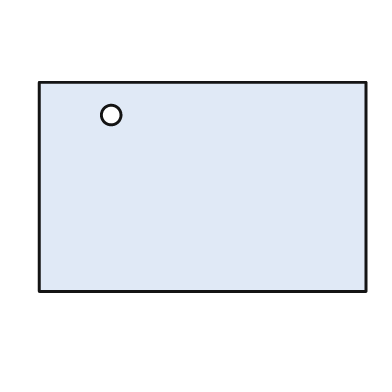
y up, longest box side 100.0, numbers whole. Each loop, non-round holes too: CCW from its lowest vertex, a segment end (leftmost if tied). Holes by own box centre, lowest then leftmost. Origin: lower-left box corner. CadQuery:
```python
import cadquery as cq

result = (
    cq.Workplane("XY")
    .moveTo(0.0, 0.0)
    .lineTo(100.0, 0.0)
    .lineTo(100.0, 64.0)
    .lineTo(0.0, 64.0)
    .close()
    .moveTo(22.0, 54.0)
    .circle(3.0)
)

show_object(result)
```